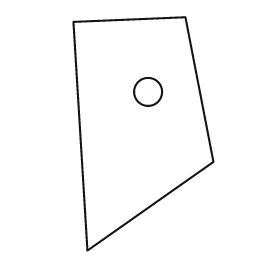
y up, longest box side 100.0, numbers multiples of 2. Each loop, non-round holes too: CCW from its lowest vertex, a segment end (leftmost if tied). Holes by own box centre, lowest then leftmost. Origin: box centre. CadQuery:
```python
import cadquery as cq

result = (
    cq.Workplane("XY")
    .moveTo(-24.0, -50.0)
    .lineTo(30.0, -12.0)
    .lineTo(18.0, 50.0)
    .lineTo(-30.0, 48.0)
    .close()
    .moveTo(2.0, 18.0)
    .circle(6.0)
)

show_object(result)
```